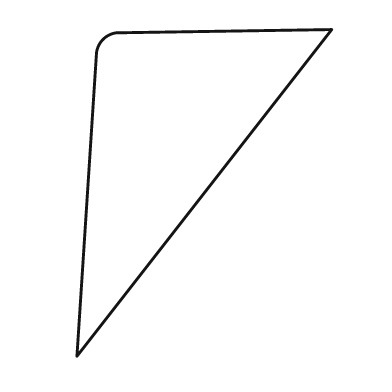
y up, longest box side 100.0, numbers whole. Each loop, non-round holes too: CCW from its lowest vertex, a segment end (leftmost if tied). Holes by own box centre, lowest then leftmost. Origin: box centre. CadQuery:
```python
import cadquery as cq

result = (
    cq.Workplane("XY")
    .moveTo(-39.0, -50.0)
    .lineTo(39.0, 50.0)
    .lineTo(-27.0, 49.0)
    .threePointArc((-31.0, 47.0), (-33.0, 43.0))
    .close()
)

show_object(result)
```